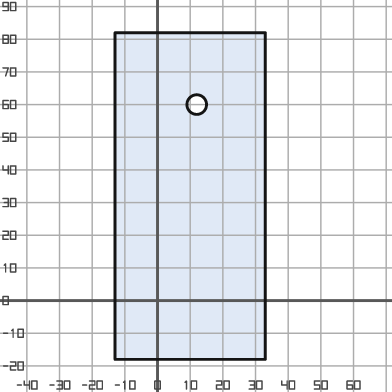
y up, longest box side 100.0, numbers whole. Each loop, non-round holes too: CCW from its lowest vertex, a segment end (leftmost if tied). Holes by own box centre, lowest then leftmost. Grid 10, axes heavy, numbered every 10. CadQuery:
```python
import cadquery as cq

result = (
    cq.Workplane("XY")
    .moveTo(-13.0, -18.0)
    .lineTo(33.0, -18.0)
    .lineTo(33.0, 82.0)
    .lineTo(-13.0, 82.0)
    .close()
    .moveTo(12.0, 60.0)
    .circle(3.0)
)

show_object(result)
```